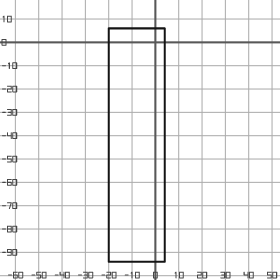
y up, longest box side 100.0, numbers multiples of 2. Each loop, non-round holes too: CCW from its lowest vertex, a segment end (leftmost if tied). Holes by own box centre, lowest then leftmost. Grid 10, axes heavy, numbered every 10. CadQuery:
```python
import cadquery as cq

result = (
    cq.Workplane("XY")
    .moveTo(-20.0, -94.0)
    .lineTo(4.0, -94.0)
    .lineTo(4.0, 6.0)
    .lineTo(-20.0, 6.0)
    .close()
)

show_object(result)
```